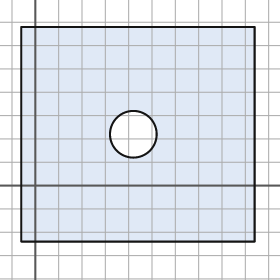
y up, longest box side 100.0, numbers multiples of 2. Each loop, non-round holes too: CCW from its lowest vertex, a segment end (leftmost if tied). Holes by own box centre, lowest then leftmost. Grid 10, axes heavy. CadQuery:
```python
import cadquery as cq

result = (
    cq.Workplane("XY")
    .moveTo(-6.0, -24.0)
    .lineTo(94.0, -24.0)
    .lineTo(94.0, 68.0)
    .lineTo(-6.0, 68.0)
    .close()
    .moveTo(42.0, 22.0)
    .circle(10.0)
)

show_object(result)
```